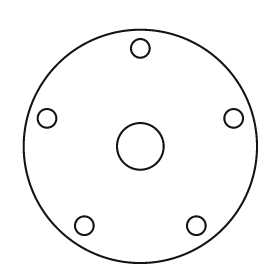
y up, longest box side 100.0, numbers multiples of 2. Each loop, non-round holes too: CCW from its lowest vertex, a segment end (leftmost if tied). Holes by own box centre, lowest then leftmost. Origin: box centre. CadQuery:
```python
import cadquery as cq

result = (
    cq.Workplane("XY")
    .moveTo(0.0, 0.0)
    .circle(50.0)
    .moveTo(-24.0, -34.0)
    .circle(4.0)
    .moveTo(24.0, -34.0)
    .circle(4.0)
    .moveTo(0.0, 0.0)
    .circle(10.0)
    .moveTo(-40.0, 12.0)
    .circle(4.0)
    .moveTo(40.0, 12.0)
    .circle(4.0)
    .moveTo(0.0, 42.0)
    .circle(4.0)
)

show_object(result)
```